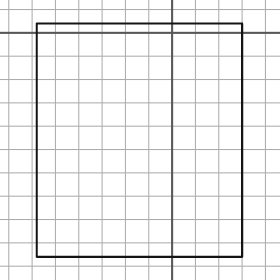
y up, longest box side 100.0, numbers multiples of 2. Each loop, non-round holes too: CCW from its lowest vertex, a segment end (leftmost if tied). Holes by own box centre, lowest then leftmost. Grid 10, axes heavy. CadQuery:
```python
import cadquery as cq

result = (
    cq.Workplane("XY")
    .moveTo(-58.0, -96.0)
    .lineTo(30.0, -96.0)
    .lineTo(30.0, 4.0)
    .lineTo(-58.0, 4.0)
    .close()
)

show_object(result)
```